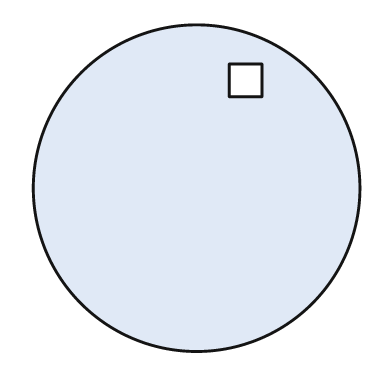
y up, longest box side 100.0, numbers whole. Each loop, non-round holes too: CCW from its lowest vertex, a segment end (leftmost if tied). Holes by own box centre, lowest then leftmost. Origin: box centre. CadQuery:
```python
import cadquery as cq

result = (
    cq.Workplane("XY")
    .moveTo(0.0, 0.0)
    .circle(50.0)
    .moveTo(10.0, 28.0)
    .lineTo(20.0, 28.0)
    .lineTo(20.0, 38.0)
    .lineTo(10.0, 38.0)
    .close()
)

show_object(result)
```